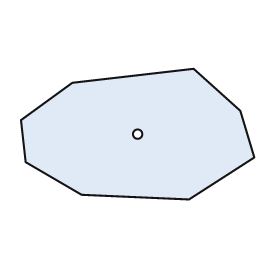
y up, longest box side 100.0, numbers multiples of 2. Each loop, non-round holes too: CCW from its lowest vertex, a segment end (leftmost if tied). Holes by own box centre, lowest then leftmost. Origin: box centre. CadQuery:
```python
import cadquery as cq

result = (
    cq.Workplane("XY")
    .moveTo(22.0, -28.0)
    .lineTo(50.0, -10.0)
    .lineTo(44.0, 10.0)
    .lineTo(24.0, 28.0)
    .lineTo(-28.0, 22.0)
    .lineTo(-50.0, 6.0)
    .lineTo(-48.0, -12.0)
    .lineTo(-24.0, -26.0)
    .close()
    .moveTo(0.0, 0.0)
    .circle(2.0)
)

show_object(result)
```